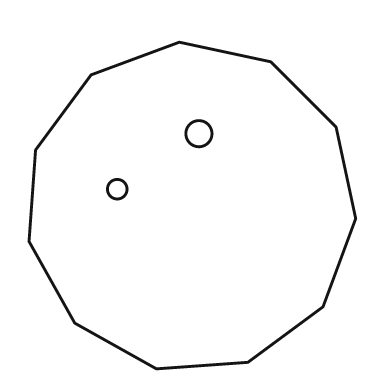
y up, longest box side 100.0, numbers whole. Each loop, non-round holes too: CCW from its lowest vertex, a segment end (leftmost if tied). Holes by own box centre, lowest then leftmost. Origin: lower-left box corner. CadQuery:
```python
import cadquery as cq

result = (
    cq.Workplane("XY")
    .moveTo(39.0, 0.0)
    .lineTo(67.0, 2.0)
    .lineTo(90.0, 19.0)
    .lineTo(100.0, 46.0)
    .lineTo(94.0, 74.0)
    .lineTo(74.0, 94.0)
    .lineTo(46.0, 100.0)
    .lineTo(19.0, 90.0)
    .lineTo(2.0, 67.0)
    .lineTo(0.0, 39.0)
    .lineTo(14.0, 14.0)
    .close()
    .moveTo(27.0, 55.0)
    .circle(3.0)
    .moveTo(52.0, 72.0)
    .circle(4.0)
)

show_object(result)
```